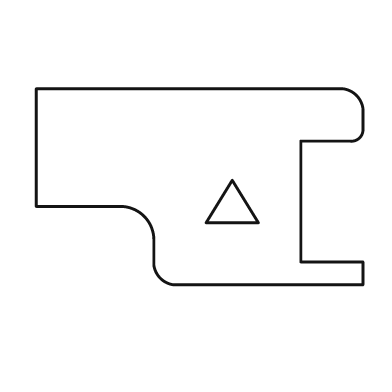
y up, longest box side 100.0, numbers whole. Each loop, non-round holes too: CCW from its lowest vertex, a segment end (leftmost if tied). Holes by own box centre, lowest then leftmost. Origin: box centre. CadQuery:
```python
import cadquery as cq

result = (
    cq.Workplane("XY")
    .moveTo(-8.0, -30.0)
    .lineTo(50.0, -30.0)
    .lineTo(50.0, -23.0)
    .lineTo(31.0, -23.0)
    .lineTo(31.0, 14.0)
    .lineTo(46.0, 14.0)
    .threePointArc((49.0, 15.0), (50.0, 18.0))
    .lineTo(50.0, 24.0)
    .threePointArc((48.0, 28.0), (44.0, 30.0))
    .lineTo(-50.0, 30.0)
    .lineTo(-50.0, -6.0)
    .lineTo(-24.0, -6.0)
    .threePointArc((-17.0, -9.0), (-14.0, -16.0))
    .lineTo(-14.0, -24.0)
    .threePointArc((-12.0, -28.0), (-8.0, -30.0))
    .close()
    .moveTo(2.0, -11.0)
    .lineTo(18.0, -11.0)
    .lineTo(10.0, 2.0)
    .close()
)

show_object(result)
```